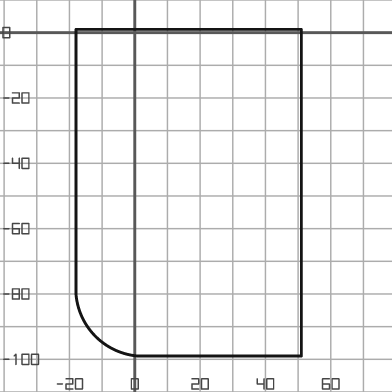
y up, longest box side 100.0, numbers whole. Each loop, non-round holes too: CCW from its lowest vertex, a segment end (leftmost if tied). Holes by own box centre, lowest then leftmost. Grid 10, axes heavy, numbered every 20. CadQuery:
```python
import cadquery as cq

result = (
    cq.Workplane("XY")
    .moveTo(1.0, -99.0)
    .lineTo(51.0, -99.0)
    .lineTo(51.0, 1.0)
    .lineTo(-18.0, 1.0)
    .lineTo(-18.0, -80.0)
    .threePointArc((-12.0, -93.0), (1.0, -99.0))
    .close()
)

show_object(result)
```